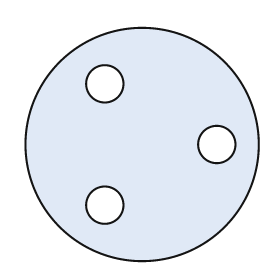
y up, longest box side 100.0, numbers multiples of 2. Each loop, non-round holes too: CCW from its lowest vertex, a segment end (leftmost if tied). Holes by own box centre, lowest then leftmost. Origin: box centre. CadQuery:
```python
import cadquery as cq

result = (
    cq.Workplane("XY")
    .moveTo(0.0, 0.0)
    .circle(50.0)
    .moveTo(-16.0, -26.0)
    .circle(8.0)
    .moveTo(32.0, 0.0)
    .circle(8.0)
    .moveTo(-16.0, 26.0)
    .circle(8.0)
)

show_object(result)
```